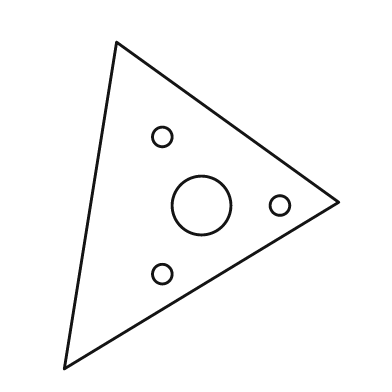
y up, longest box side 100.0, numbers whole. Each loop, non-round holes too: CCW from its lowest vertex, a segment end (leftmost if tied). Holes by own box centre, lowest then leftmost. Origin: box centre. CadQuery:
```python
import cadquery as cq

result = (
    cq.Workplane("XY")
    .moveTo(-42.0, -50.0)
    .lineTo(42.0, 1.0)
    .lineTo(-26.0, 50.0)
    .close()
    .moveTo(-12.0, -21.0)
    .circle(3.0)
    .moveTo(0.0, 0.0)
    .circle(9.0)
    .moveTo(24.0, 0.0)
    .circle(3.0)
    .moveTo(-12.0, 21.0)
    .circle(3.0)
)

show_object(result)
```